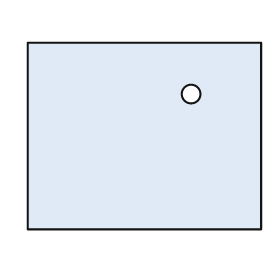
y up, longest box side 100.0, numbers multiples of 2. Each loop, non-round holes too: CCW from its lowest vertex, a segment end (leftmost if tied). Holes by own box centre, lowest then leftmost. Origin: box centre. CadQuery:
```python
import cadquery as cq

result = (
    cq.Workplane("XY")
    .moveTo(-50.0, -40.0)
    .lineTo(50.0, -40.0)
    .lineTo(50.0, 40.0)
    .lineTo(-50.0, 40.0)
    .close()
    .moveTo(20.0, 18.0)
    .circle(4.0)
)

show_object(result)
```